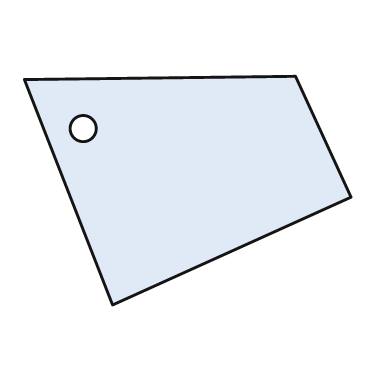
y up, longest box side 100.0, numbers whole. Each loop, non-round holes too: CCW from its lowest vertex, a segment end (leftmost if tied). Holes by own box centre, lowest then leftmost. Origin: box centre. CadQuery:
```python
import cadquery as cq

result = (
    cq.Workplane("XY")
    .moveTo(-23.0, -35.0)
    .lineTo(50.0, -2.0)
    .lineTo(33.0, 35.0)
    .lineTo(-50.0, 34.0)
    .close()
    .moveTo(-32.0, 19.0)
    .circle(4.0)
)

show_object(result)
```